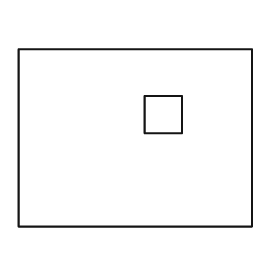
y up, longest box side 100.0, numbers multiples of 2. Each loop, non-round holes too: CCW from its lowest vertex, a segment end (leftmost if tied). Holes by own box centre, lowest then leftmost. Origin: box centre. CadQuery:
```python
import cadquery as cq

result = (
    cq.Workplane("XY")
    .moveTo(-50.0, -38.0)
    .lineTo(50.0, -38.0)
    .lineTo(50.0, 38.0)
    .lineTo(-50.0, 38.0)
    .close()
    .moveTo(4.0, 2.0)
    .lineTo(20.0, 2.0)
    .lineTo(20.0, 18.0)
    .lineTo(4.0, 18.0)
    .close()
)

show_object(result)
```